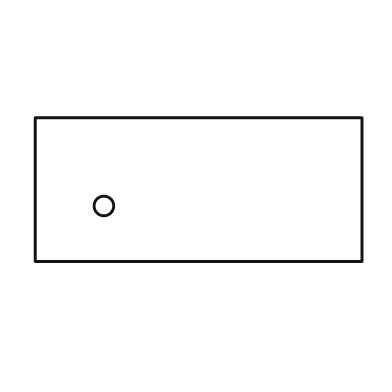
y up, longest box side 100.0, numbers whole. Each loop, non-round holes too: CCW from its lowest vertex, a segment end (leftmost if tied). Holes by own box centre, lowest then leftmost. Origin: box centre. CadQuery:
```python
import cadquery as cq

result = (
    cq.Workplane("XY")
    .moveTo(-50.0, -22.0)
    .lineTo(50.0, -22.0)
    .lineTo(50.0, 22.0)
    .lineTo(-50.0, 22.0)
    .close()
    .moveTo(-29.0, -5.0)
    .circle(3.0)
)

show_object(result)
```